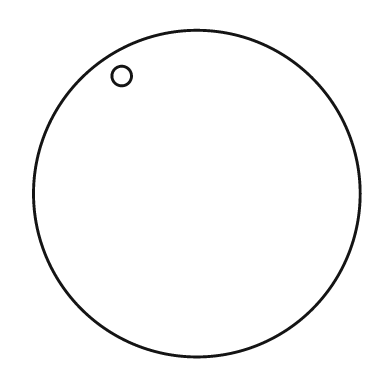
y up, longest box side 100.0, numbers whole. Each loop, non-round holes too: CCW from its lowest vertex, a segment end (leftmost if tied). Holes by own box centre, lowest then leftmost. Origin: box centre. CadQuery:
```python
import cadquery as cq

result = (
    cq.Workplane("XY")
    .moveTo(0.0, 0.0)
    .circle(50.0)
    .moveTo(-23.0, 36.0)
    .circle(3.0)
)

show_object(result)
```